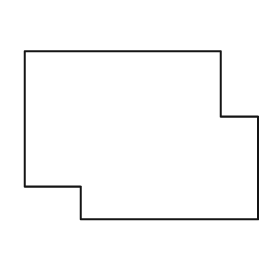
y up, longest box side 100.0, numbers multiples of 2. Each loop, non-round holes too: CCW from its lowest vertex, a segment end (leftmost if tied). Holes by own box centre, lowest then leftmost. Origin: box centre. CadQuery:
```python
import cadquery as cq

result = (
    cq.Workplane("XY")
    .moveTo(-26.0, -36.0)
    .lineTo(50.0, -36.0)
    .lineTo(50.0, 8.0)
    .lineTo(34.0, 8.0)
    .lineTo(34.0, 36.0)
    .lineTo(-50.0, 36.0)
    .lineTo(-50.0, -22.0)
    .lineTo(-26.0, -22.0)
    .close()
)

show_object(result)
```